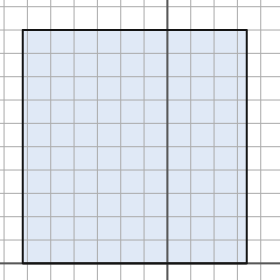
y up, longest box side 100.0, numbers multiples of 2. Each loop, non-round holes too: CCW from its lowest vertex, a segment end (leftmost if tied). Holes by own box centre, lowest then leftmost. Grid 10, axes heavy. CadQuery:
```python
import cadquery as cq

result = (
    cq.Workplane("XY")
    .moveTo(-62.0, 0.0)
    .lineTo(34.0, 0.0)
    .lineTo(34.0, 100.0)
    .lineTo(-62.0, 100.0)
    .close()
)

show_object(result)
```